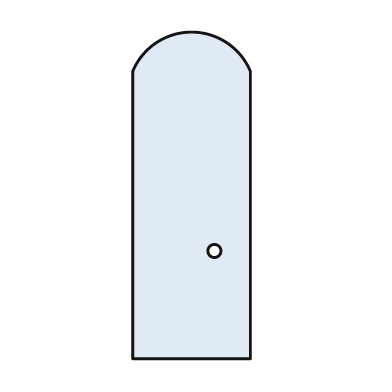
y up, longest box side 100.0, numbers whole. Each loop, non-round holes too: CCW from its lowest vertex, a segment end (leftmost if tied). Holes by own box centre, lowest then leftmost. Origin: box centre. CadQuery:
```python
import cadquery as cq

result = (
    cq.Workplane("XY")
    .moveTo(-18.0, -50.0)
    .lineTo(18.0, -50.0)
    .lineTo(18.0, 38.0)
    .threePointArc((0.0, 50.0), (-18.0, 38.0))
    .close()
    .moveTo(7.0, -17.0)
    .circle(2.0)
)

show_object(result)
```